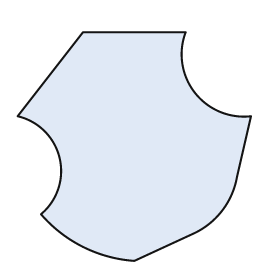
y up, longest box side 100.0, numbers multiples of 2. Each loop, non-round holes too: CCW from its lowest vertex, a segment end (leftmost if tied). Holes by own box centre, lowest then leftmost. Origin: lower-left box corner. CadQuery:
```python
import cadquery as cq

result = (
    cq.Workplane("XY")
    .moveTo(50.0, 0.0)
    .lineTo(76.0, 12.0)
    .threePointArc((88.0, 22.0), (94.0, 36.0))
    .lineTo(100.0, 62.0)
    .threePointArc((76.0, 72.0), (72.0, 98.0))
    .lineTo(28.0, 98.0)
    .lineTo(0.0, 62.0)
    .threePointArc((18.0, 44.0), (10.0, 20.0))
    .threePointArc((28.0, 6.0), (50.0, 0.0))
    .close()
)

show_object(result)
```